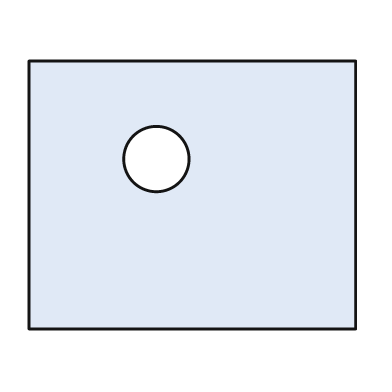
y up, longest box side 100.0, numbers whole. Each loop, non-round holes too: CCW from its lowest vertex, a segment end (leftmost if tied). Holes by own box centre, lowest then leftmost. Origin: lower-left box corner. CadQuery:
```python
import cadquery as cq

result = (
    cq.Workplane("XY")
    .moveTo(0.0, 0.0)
    .lineTo(100.0, 0.0)
    .lineTo(100.0, 82.0)
    .lineTo(0.0, 82.0)
    .close()
    .moveTo(39.0, 52.0)
    .circle(10.0)
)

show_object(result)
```